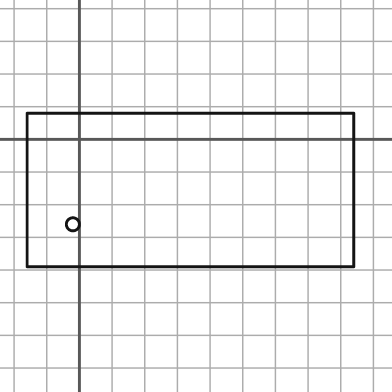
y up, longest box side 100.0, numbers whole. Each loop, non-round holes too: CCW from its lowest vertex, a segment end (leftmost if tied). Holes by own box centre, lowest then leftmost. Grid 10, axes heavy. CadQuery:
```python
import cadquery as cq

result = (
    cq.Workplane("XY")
    .moveTo(-16.0, -39.0)
    .lineTo(84.0, -39.0)
    .lineTo(84.0, 8.0)
    .lineTo(-16.0, 8.0)
    .close()
    .moveTo(-2.0, -26.0)
    .circle(2.0)
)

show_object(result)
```